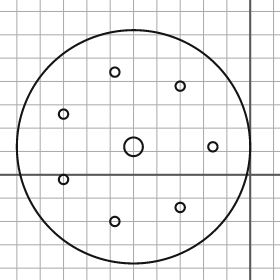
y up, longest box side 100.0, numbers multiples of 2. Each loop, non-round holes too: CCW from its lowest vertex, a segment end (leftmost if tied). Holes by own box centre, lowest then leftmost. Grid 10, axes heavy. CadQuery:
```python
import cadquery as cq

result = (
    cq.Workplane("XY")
    .moveTo(-50.0, 12.0)
    .circle(50.0)
    .moveTo(-58.0, -20.0)
    .circle(2.0)
    .moveTo(-30.0, -14.0)
    .circle(2.0)
    .moveTo(-80.0, -2.0)
    .circle(2.0)
    .moveTo(-50.0, 12.0)
    .circle(4.0)
    .moveTo(-16.0, 12.0)
    .circle(2.0)
    .moveTo(-80.0, 26.0)
    .circle(2.0)
    .moveTo(-30.0, 38.0)
    .circle(2.0)
    .moveTo(-58.0, 44.0)
    .circle(2.0)
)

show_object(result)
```